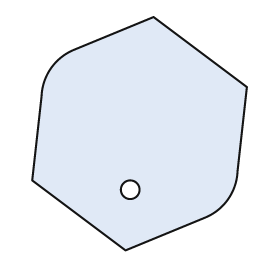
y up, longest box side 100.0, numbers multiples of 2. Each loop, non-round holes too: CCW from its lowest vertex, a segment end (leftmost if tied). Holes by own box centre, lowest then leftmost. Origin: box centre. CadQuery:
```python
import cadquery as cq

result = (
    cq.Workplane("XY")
    .moveTo(-6.0, -50.0)
    .lineTo(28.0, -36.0)
    .threePointArc((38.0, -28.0), (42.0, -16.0))
    .lineTo(46.0, 20.0)
    .lineTo(6.0, 50.0)
    .lineTo(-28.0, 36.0)
    .threePointArc((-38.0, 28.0), (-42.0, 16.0))
    .lineTo(-46.0, -20.0)
    .close()
    .moveTo(-4.0, -24.0)
    .circle(4.0)
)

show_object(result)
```